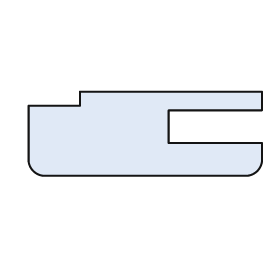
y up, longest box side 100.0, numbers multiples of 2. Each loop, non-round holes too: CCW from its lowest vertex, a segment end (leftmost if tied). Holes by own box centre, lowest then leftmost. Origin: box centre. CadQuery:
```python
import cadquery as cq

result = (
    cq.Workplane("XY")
    .moveTo(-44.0, -18.0)
    .lineTo(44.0, -18.0)
    .threePointArc((48.0, -16.0), (50.0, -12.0))
    .lineTo(50.0, -4.0)
    .lineTo(10.0, -4.0)
    .lineTo(10.0, 10.0)
    .lineTo(50.0, 10.0)
    .lineTo(50.0, 18.0)
    .lineTo(-28.0, 18.0)
    .lineTo(-28.0, 12.0)
    .lineTo(-50.0, 12.0)
    .lineTo(-50.0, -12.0)
    .threePointArc((-48.0, -16.0), (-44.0, -18.0))
    .close()
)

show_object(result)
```